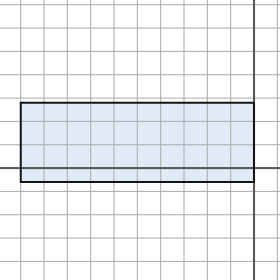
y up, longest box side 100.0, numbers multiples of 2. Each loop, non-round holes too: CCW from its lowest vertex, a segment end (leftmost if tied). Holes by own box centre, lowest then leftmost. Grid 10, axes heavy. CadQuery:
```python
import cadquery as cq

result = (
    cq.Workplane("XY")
    .moveTo(-100.0, -6.0)
    .lineTo(0.0, -6.0)
    .lineTo(0.0, 28.0)
    .lineTo(-100.0, 28.0)
    .close()
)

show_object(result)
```